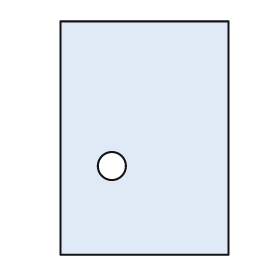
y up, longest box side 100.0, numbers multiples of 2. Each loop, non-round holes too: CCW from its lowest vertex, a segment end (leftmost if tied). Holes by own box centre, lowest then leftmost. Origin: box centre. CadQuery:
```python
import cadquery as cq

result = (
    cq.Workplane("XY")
    .moveTo(-36.0, -50.0)
    .lineTo(36.0, -50.0)
    .lineTo(36.0, 50.0)
    .lineTo(-36.0, 50.0)
    .close()
    .moveTo(-14.0, -12.0)
    .circle(6.0)
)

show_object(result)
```